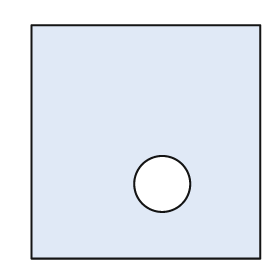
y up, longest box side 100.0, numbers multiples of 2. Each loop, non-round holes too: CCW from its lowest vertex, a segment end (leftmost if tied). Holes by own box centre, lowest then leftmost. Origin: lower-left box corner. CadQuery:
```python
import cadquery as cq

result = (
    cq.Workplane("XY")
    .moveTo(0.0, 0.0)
    .lineTo(98.0, 0.0)
    .lineTo(98.0, 100.0)
    .lineTo(0.0, 100.0)
    .close()
    .moveTo(56.0, 32.0)
    .circle(12.0)
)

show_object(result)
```